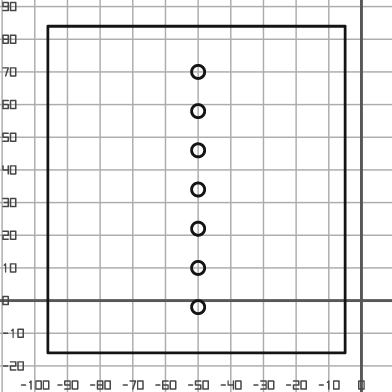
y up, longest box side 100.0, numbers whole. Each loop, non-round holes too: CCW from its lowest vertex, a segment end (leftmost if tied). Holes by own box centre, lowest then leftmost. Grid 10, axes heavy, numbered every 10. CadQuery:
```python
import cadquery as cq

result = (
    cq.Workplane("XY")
    .moveTo(-96.0, -16.0)
    .lineTo(-5.0, -16.0)
    .lineTo(-5.0, 84.0)
    .lineTo(-96.0, 84.0)
    .close()
    .moveTo(-50.0, -2.0)
    .circle(2.0)
    .moveTo(-50.0, 10.0)
    .circle(2.0)
    .moveTo(-50.0, 22.0)
    .circle(2.0)
    .moveTo(-50.0, 34.0)
    .circle(2.0)
    .moveTo(-50.0, 46.0)
    .circle(2.0)
    .moveTo(-50.0, 58.0)
    .circle(2.0)
    .moveTo(-50.0, 70.0)
    .circle(2.0)
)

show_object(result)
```